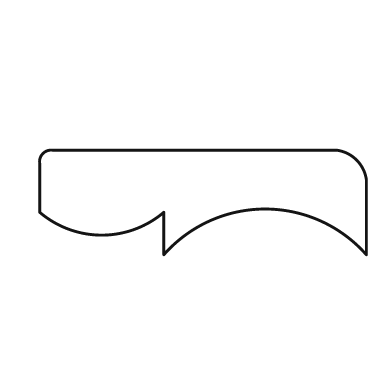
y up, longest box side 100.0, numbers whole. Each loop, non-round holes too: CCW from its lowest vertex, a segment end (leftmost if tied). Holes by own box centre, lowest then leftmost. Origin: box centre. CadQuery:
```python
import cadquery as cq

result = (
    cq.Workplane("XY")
    .moveTo(-12.0, -16.0)
    .threePointArc((19.0, -2.0), (50.0, -16.0))
    .lineTo(50.0, 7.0)
    .threePointArc((47.0, 13.0), (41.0, 16.0))
    .lineTo(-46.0, 16.0)
    .threePointArc((-49.0, 15.0), (-50.0, 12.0))
    .lineTo(-50.0, -3.0)
    .threePointArc((-31.0, -10.0), (-12.0, -3.0))
    .close()
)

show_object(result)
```